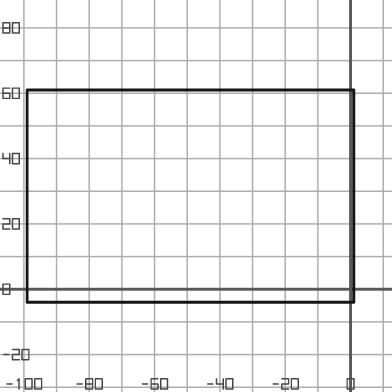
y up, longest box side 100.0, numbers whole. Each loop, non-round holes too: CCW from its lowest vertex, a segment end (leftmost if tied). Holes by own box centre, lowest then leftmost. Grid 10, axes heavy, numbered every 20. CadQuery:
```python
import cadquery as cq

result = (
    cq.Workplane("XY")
    .moveTo(-99.0, -4.0)
    .lineTo(1.0, -4.0)
    .lineTo(1.0, 61.0)
    .lineTo(-99.0, 61.0)
    .close()
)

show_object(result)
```